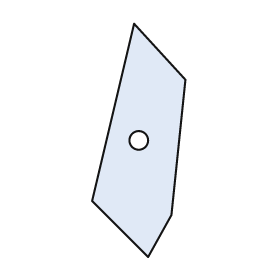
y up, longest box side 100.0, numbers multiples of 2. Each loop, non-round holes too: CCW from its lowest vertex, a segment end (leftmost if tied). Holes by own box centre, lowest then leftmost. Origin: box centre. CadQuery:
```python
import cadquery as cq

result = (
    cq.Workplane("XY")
    .moveTo(4.0, -50.0)
    .lineTo(14.0, -32.0)
    .lineTo(20.0, 26.0)
    .lineTo(-2.0, 50.0)
    .lineTo(-20.0, -26.0)
    .close()
    .moveTo(0.0, 0.0)
    .circle(4.0)
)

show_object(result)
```